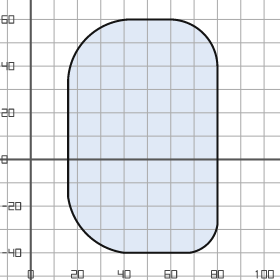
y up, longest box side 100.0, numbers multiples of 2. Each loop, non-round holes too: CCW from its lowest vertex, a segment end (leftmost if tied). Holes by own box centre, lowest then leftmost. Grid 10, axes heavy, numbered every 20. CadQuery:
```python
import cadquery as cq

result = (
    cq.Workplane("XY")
    .moveTo(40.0, -40.0)
    .lineTo(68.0, -40.0)
    .threePointArc((76.0, -36.0), (80.0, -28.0))
    .lineTo(80.0, 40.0)
    .threePointArc((74.0, 54.0), (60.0, 60.0))
    .lineTo(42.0, 60.0)
    .threePointArc((24.0, 52.0), (16.0, 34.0))
    .lineTo(16.0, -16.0)
    .threePointArc((24.0, -32.0), (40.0, -40.0))
    .close()
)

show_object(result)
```